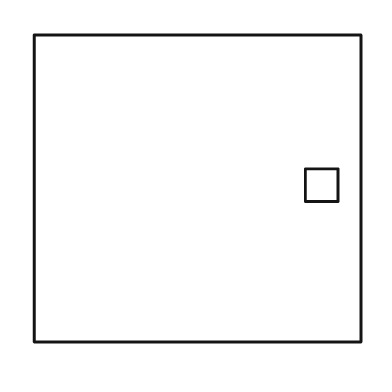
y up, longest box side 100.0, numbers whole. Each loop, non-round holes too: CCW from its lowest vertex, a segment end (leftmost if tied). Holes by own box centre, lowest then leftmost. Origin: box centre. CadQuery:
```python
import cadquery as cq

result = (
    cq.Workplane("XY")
    .moveTo(-50.0, -47.0)
    .lineTo(50.0, -47.0)
    .lineTo(50.0, 47.0)
    .lineTo(-50.0, 47.0)
    .close()
    .moveTo(33.0, -4.0)
    .lineTo(43.0, -4.0)
    .lineTo(43.0, 6.0)
    .lineTo(33.0, 6.0)
    .close()
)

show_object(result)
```